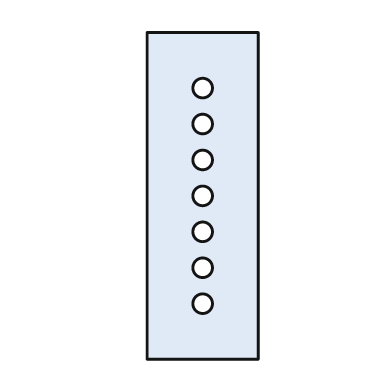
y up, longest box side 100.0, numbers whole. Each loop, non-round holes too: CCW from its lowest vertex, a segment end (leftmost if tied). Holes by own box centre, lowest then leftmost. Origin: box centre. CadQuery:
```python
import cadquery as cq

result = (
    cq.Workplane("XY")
    .moveTo(-17.0, -50.0)
    .lineTo(17.0, -50.0)
    .lineTo(17.0, 50.0)
    .lineTo(-17.0, 50.0)
    .close()
    .moveTo(0.0, -33.0)
    .circle(3.0)
    .moveTo(0.0, -22.0)
    .circle(3.0)
    .moveTo(0.0, -11.0)
    .circle(3.0)
    .moveTo(0.0, 0.0)
    .circle(3.0)
    .moveTo(0.0, 11.0)
    .circle(3.0)
    .moveTo(0.0, 22.0)
    .circle(3.0)
    .moveTo(0.0, 33.0)
    .circle(3.0)
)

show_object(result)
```